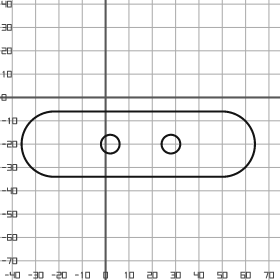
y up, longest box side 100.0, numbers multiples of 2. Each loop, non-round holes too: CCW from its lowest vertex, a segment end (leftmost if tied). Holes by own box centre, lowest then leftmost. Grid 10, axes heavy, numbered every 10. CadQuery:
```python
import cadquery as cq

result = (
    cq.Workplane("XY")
    .moveTo(-22.0, -34.0)
    .lineTo(50.0, -34.0)
    .threePointArc((64.0, -20.0), (50.0, -6.0))
    .lineTo(-22.0, -6.0)
    .threePointArc((-36.0, -20.0), (-22.0, -34.0))
    .close()
    .moveTo(2.0, -20.0)
    .circle(4.0)
    .moveTo(28.0, -20.0)
    .circle(4.0)
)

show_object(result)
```